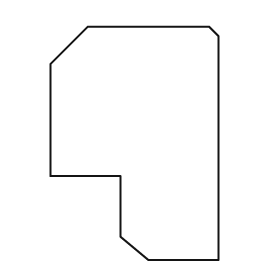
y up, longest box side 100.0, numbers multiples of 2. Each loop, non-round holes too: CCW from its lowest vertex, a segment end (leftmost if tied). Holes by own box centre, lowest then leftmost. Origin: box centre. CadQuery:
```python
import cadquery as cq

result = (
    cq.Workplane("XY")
    .moveTo(6.0, -50.0)
    .lineTo(36.0, -50.0)
    .lineTo(36.0, 46.0)
    .lineTo(32.0, 50.0)
    .lineTo(-20.0, 50.0)
    .lineTo(-36.0, 34.0)
    .lineTo(-36.0, -14.0)
    .lineTo(-6.0, -14.0)
    .lineTo(-6.0, -40.0)
    .close()
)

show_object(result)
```